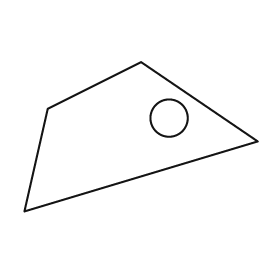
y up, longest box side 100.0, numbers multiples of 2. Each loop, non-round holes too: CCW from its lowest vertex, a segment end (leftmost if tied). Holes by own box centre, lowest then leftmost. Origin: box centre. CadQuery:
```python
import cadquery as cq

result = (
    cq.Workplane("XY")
    .moveTo(-50.0, -32.0)
    .lineTo(50.0, -2.0)
    .lineTo(0.0, 32.0)
    .lineTo(-40.0, 12.0)
    .close()
    .moveTo(12.0, 8.0)
    .circle(8.0)
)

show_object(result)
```